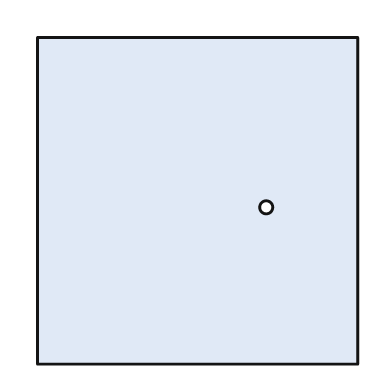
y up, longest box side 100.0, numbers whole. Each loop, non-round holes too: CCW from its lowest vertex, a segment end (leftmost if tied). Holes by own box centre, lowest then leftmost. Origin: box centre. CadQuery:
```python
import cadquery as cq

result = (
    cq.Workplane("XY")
    .moveTo(-49.0, -50.0)
    .lineTo(49.0, -50.0)
    .lineTo(49.0, 50.0)
    .lineTo(-49.0, 50.0)
    .close()
    .moveTo(21.0, -2.0)
    .circle(2.0)
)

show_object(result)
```